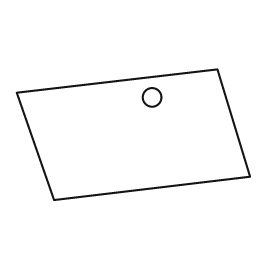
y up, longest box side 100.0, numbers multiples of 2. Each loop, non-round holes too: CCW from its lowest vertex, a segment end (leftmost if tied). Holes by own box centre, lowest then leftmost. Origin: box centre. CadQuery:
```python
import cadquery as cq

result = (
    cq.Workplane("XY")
    .moveTo(-34.0, -28.0)
    .lineTo(50.0, -18.0)
    .lineTo(36.0, 28.0)
    .lineTo(-50.0, 18.0)
    .close()
    .moveTo(8.0, 16.0)
    .circle(4.0)
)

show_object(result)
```